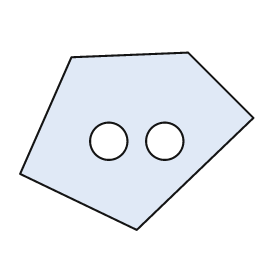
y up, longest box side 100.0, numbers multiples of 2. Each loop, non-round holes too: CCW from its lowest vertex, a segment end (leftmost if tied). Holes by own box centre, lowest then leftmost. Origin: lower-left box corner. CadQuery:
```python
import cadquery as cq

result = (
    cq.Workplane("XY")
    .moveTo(50.0, 0.0)
    .lineTo(100.0, 48.0)
    .lineTo(72.0, 76.0)
    .lineTo(22.0, 74.0)
    .lineTo(0.0, 24.0)
    .close()
    .moveTo(38.0, 38.0)
    .circle(8.0)
    .moveTo(62.0, 38.0)
    .circle(8.0)
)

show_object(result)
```